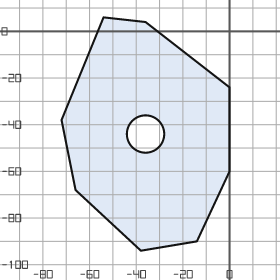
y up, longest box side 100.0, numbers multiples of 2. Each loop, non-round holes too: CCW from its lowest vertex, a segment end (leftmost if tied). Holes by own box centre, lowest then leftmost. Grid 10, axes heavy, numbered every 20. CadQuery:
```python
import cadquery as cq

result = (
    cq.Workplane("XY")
    .moveTo(-38.0, -94.0)
    .lineTo(-14.0, -90.0)
    .lineTo(0.0, -60.0)
    .lineTo(0.0, -24.0)
    .lineTo(-36.0, 4.0)
    .lineTo(-54.0, 6.0)
    .lineTo(-72.0, -38.0)
    .lineTo(-66.0, -68.0)
    .close()
    .moveTo(-36.0, -44.0)
    .circle(8.0)
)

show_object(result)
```